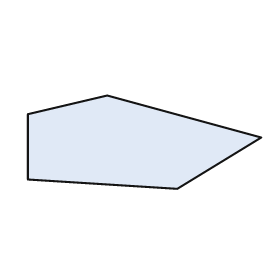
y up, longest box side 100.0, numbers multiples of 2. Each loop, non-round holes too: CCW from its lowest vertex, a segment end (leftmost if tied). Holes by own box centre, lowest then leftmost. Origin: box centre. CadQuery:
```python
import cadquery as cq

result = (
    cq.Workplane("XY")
    .moveTo(14.0, -20.0)
    .lineTo(50.0, 2.0)
    .lineTo(-16.0, 20.0)
    .lineTo(-50.0, 12.0)
    .lineTo(-50.0, -16.0)
    .close()
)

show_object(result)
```